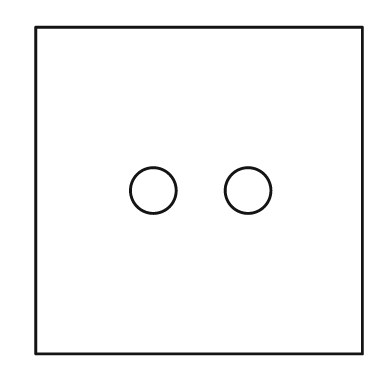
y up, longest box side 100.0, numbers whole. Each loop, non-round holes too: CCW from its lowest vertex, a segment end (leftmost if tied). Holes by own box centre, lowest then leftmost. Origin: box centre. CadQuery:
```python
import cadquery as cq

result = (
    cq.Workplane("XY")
    .moveTo(-50.0, -50.0)
    .lineTo(50.0, -50.0)
    .lineTo(50.0, 50.0)
    .lineTo(-50.0, 50.0)
    .close()
    .moveTo(-14.0, 0.0)
    .circle(7.0)
    .moveTo(15.0, 0.0)
    .circle(7.0)
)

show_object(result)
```